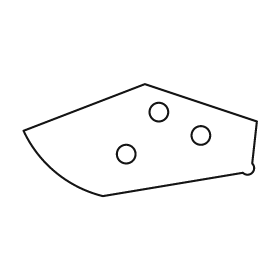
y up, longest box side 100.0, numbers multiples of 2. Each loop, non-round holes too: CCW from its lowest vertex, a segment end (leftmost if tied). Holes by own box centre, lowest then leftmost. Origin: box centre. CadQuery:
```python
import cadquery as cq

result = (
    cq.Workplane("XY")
    .moveTo(-16.0, -24.0)
    .lineTo(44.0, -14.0)
    .threePointArc((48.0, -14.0), (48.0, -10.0))
    .lineTo(50.0, 8.0)
    .lineTo(2.0, 24.0)
    .lineTo(-50.0, 4.0)
    .threePointArc((-36.0, -14.0), (-16.0, -24.0))
    .close()
    .moveTo(-6.0, -6.0)
    .circle(4.0)
    .moveTo(26.0, 2.0)
    .circle(4.0)
    .moveTo(8.0, 12.0)
    .circle(4.0)
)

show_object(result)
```